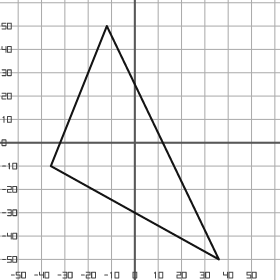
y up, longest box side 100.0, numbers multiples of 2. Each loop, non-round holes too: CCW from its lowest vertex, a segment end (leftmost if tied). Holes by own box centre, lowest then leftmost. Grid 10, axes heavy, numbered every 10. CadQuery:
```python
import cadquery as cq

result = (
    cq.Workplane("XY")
    .moveTo(36.0, -50.0)
    .lineTo(-12.0, 50.0)
    .lineTo(-36.0, -10.0)
    .close()
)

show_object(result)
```